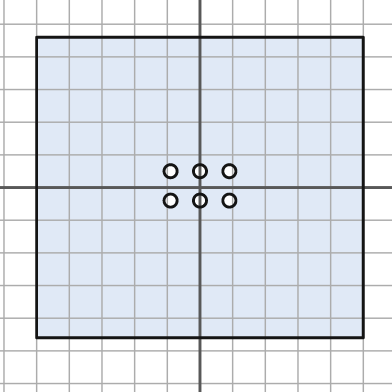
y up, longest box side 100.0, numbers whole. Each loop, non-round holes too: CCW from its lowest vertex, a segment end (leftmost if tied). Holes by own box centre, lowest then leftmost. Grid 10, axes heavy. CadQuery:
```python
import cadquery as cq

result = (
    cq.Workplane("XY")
    .moveTo(-50.0, -46.0)
    .lineTo(50.0, -46.0)
    .lineTo(50.0, 46.0)
    .lineTo(-50.0, 46.0)
    .close()
    .moveTo(-9.0, -4.0)
    .circle(2.0)
    .moveTo(0.0, -4.0)
    .circle(2.0)
    .moveTo(9.0, -4.0)
    .circle(2.0)
    .moveTo(-9.0, 5.0)
    .circle(2.0)
    .moveTo(0.0, 5.0)
    .circle(2.0)
    .moveTo(9.0, 5.0)
    .circle(2.0)
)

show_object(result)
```